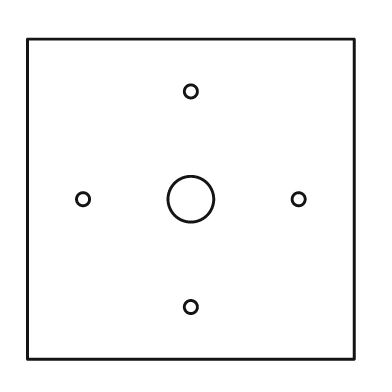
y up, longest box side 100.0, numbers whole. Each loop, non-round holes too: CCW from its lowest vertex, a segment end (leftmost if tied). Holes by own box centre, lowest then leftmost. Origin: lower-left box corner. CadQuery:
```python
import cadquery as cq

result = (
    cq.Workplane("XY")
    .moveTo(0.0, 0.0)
    .lineTo(100.0, 0.0)
    .lineTo(100.0, 98.0)
    .lineTo(0.0, 98.0)
    .close()
    .moveTo(50.0, 16.0)
    .circle(2.0)
    .moveTo(17.0, 49.0)
    .circle(2.0)
    .moveTo(50.0, 49.0)
    .circle(7.0)
    .moveTo(83.0, 49.0)
    .circle(2.0)
    .moveTo(50.0, 82.0)
    .circle(2.0)
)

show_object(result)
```